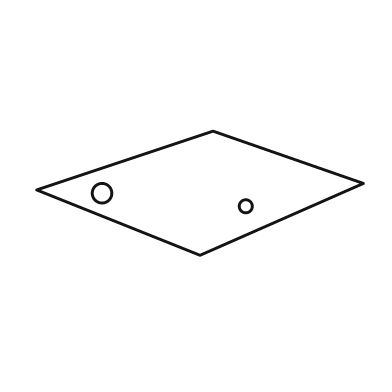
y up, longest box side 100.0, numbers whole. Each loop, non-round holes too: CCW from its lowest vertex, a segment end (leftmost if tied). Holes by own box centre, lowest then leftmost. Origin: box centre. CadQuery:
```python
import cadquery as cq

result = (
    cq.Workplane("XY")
    .moveTo(0.0, -19.0)
    .lineTo(50.0, 3.0)
    .lineTo(4.0, 19.0)
    .lineTo(-50.0, 1.0)
    .close()
    .moveTo(14.0, -4.0)
    .circle(2.0)
    .moveTo(-30.0, 0.0)
    .circle(3.0)
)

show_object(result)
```